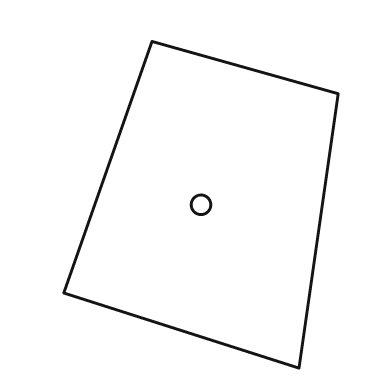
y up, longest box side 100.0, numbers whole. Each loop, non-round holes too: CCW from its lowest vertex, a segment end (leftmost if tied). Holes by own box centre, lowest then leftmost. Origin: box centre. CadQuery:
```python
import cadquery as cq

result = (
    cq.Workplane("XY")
    .moveTo(30.0, -50.0)
    .lineTo(42.0, 34.0)
    .lineTo(-15.0, 50.0)
    .lineTo(-42.0, -27.0)
    .close()
    .moveTo(0.0, 0.0)
    .circle(3.0)
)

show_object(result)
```